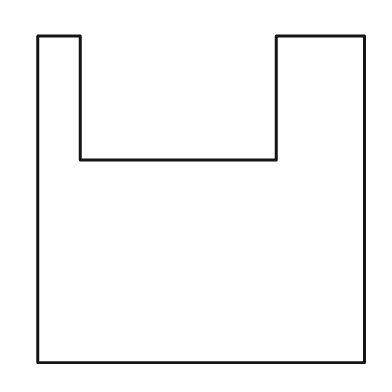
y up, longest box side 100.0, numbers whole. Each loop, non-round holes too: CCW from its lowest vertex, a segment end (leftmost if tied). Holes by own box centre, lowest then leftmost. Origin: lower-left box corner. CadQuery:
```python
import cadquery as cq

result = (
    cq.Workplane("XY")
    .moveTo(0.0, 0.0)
    .lineTo(100.0, 0.0)
    .lineTo(100.0, 100.0)
    .lineTo(73.0, 100.0)
    .lineTo(73.0, 62.0)
    .lineTo(13.0, 62.0)
    .lineTo(13.0, 100.0)
    .lineTo(0.0, 100.0)
    .close()
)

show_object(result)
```